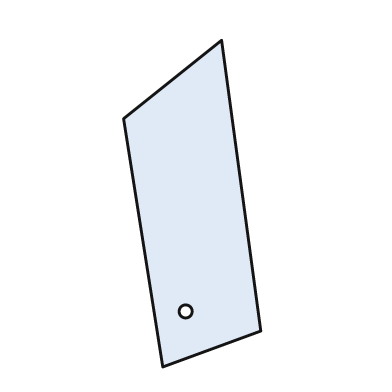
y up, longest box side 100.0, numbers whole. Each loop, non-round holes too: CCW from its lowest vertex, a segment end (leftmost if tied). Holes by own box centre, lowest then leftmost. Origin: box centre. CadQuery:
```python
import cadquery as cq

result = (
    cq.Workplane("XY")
    .moveTo(-9.0, -50.0)
    .lineTo(21.0, -39.0)
    .lineTo(9.0, 50.0)
    .lineTo(-21.0, 26.0)
    .close()
    .moveTo(-2.0, -33.0)
    .circle(2.0)
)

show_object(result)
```